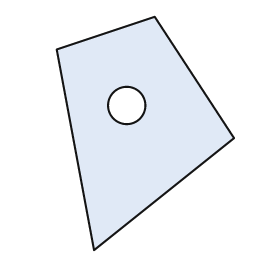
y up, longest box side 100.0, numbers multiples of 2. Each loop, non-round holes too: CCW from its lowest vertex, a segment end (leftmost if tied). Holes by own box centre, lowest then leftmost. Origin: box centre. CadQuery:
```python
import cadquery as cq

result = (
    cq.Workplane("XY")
    .moveTo(-22.0, -50.0)
    .lineTo(38.0, -2.0)
    .lineTo(4.0, 50.0)
    .lineTo(-38.0, 36.0)
    .close()
    .moveTo(-8.0, 12.0)
    .circle(8.0)
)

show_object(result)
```